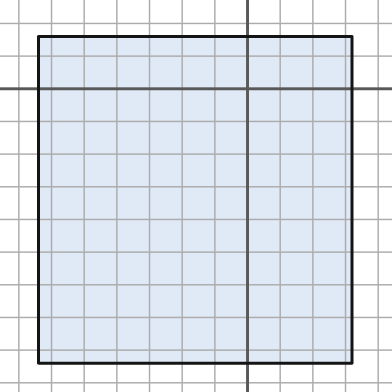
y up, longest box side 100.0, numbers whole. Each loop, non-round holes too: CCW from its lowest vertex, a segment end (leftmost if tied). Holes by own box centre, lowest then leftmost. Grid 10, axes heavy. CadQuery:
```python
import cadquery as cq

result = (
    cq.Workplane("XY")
    .moveTo(-64.0, -84.0)
    .lineTo(32.0, -84.0)
    .lineTo(32.0, 16.0)
    .lineTo(-64.0, 16.0)
    .close()
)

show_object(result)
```